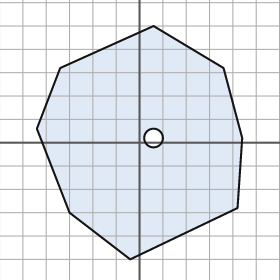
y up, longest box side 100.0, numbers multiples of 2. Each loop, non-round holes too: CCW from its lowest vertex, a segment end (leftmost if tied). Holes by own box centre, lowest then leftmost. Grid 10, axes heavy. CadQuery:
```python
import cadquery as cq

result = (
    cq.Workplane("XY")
    .moveTo(-4.0, -50.0)
    .lineTo(42.0, -28.0)
    .lineTo(44.0, 2.0)
    .lineTo(36.0, 32.0)
    .lineTo(6.0, 50.0)
    .lineTo(-34.0, 32.0)
    .lineTo(-44.0, 6.0)
    .lineTo(-30.0, -30.0)
    .close()
    .moveTo(6.0, 2.0)
    .circle(4.0)
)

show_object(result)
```